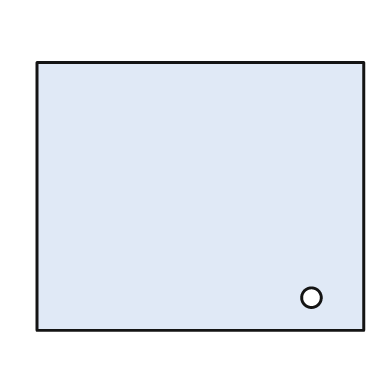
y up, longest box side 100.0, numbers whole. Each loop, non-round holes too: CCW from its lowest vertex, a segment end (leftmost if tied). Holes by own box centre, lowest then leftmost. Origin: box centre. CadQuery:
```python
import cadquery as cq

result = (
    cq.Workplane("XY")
    .moveTo(-50.0, -41.0)
    .lineTo(50.0, -41.0)
    .lineTo(50.0, 41.0)
    .lineTo(-50.0, 41.0)
    .close()
    .moveTo(34.0, -31.0)
    .circle(3.0)
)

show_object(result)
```